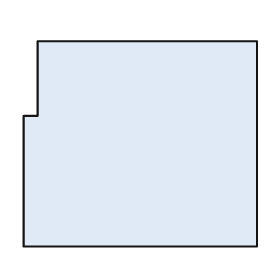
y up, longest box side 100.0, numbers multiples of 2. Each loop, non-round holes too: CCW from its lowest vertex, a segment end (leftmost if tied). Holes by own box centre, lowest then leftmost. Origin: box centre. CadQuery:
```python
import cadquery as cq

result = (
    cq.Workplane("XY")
    .moveTo(-50.0, -44.0)
    .lineTo(50.0, -44.0)
    .lineTo(50.0, 44.0)
    .lineTo(-44.0, 44.0)
    .lineTo(-44.0, 12.0)
    .lineTo(-50.0, 12.0)
    .close()
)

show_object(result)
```